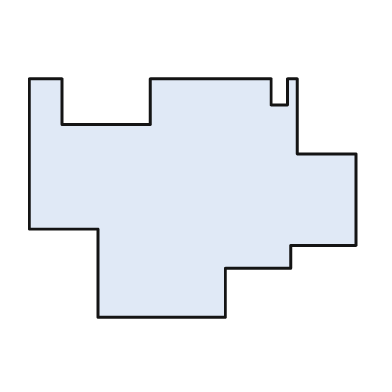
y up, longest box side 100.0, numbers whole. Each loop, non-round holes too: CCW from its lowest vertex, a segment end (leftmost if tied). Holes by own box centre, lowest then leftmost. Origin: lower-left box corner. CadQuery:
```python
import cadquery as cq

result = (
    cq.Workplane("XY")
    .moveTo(21.0, 0.0)
    .lineTo(60.0, 0.0)
    .lineTo(60.0, 15.0)
    .lineTo(80.0, 15.0)
    .lineTo(80.0, 22.0)
    .lineTo(100.0, 22.0)
    .lineTo(100.0, 50.0)
    .lineTo(82.0, 50.0)
    .lineTo(82.0, 73.0)
    .lineTo(79.0, 73.0)
    .lineTo(79.0, 65.0)
    .lineTo(74.0, 65.0)
    .lineTo(74.0, 73.0)
    .lineTo(37.0, 73.0)
    .lineTo(37.0, 59.0)
    .lineTo(10.0, 59.0)
    .lineTo(10.0, 73.0)
    .lineTo(0.0, 73.0)
    .lineTo(0.0, 27.0)
    .lineTo(21.0, 27.0)
    .close()
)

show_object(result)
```